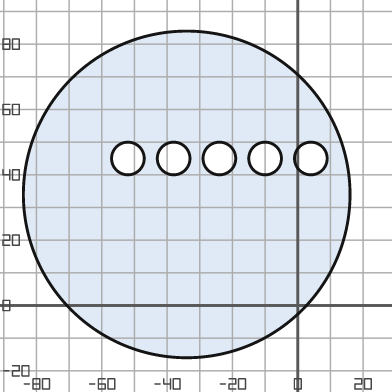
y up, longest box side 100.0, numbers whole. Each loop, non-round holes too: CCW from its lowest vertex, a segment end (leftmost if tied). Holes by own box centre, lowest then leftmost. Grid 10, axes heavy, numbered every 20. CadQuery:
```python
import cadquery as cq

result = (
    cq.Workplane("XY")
    .moveTo(-34.0, 34.0)
    .circle(50.0)
    .moveTo(-52.0, 45.0)
    .circle(5.0)
    .moveTo(-38.0, 45.0)
    .circle(5.0)
    .moveTo(-24.0, 45.0)
    .circle(5.0)
    .moveTo(-10.0, 45.0)
    .circle(5.0)
    .moveTo(4.0, 45.0)
    .circle(5.0)
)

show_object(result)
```